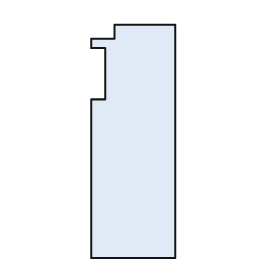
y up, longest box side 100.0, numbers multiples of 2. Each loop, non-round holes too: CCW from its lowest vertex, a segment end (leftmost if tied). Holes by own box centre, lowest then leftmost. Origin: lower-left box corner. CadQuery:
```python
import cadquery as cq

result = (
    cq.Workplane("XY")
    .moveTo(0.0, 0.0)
    .lineTo(36.0, 0.0)
    .lineTo(36.0, 100.0)
    .lineTo(10.0, 100.0)
    .lineTo(10.0, 94.0)
    .lineTo(0.0, 94.0)
    .lineTo(0.0, 90.0)
    .lineTo(6.0, 90.0)
    .lineTo(6.0, 68.0)
    .lineTo(0.0, 68.0)
    .close()
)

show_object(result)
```